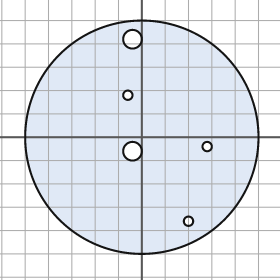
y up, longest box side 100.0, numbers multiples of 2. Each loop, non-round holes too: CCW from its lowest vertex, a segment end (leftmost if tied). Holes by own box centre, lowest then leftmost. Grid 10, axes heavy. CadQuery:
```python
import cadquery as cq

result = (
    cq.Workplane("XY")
    .moveTo(0.0, 0.0)
    .circle(50.0)
    .moveTo(20.0, -36.0)
    .circle(2.0)
    .moveTo(-4.0, -6.0)
    .circle(4.0)
    .moveTo(28.0, -4.0)
    .circle(2.0)
    .moveTo(-6.0, 18.0)
    .circle(2.0)
    .moveTo(-4.0, 42.0)
    .circle(4.0)
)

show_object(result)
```